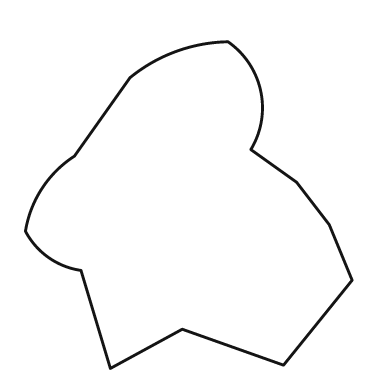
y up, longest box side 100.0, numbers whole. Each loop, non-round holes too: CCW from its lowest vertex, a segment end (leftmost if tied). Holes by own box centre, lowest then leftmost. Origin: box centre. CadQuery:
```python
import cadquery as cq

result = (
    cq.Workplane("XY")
    .moveTo(-24.0, -50.0)
    .lineTo(-2.0, -38.0)
    .lineTo(29.0, -49.0)
    .lineTo(50.0, -23.0)
    .lineTo(43.0, -6.0)
    .lineTo(33.0, 7.0)
    .lineTo(19.0, 17.0)
    .threePointArc((22.0, 35.0), (12.0, 50.0))
    .threePointArc((-4.0, 47.0), (-18.0, 39.0))
    .lineTo(-35.0, 15.0)
    .threePointArc((-45.0, 5.0), (-50.0, -8.0))
    .threePointArc((-43.0, -16.0), (-33.0, -20.0))
    .close()
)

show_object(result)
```